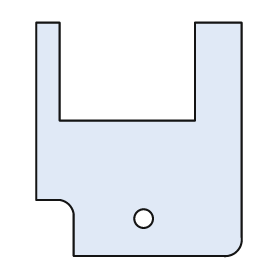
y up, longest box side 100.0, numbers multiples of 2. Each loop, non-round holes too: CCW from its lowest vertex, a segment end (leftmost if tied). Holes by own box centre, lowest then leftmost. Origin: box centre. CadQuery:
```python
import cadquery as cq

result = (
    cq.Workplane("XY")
    .moveTo(-28.0, -50.0)
    .lineTo(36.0, -50.0)
    .threePointArc((42.0, -48.0), (44.0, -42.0))
    .lineTo(44.0, 50.0)
    .lineTo(24.0, 50.0)
    .lineTo(24.0, 8.0)
    .lineTo(-34.0, 8.0)
    .lineTo(-34.0, 50.0)
    .lineTo(-44.0, 50.0)
    .lineTo(-44.0, -26.0)
    .lineTo(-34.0, -26.0)
    .threePointArc((-30.0, -28.0), (-28.0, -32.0))
    .close()
    .moveTo(2.0, -34.0)
    .circle(4.0)
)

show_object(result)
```